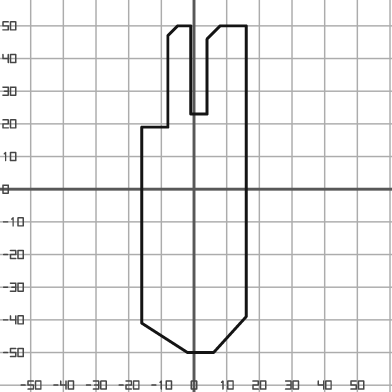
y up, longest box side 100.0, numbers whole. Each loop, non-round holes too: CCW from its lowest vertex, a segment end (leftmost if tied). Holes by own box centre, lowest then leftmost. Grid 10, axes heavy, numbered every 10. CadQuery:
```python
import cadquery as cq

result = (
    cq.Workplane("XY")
    .moveTo(-2.0, -50.0)
    .lineTo(6.0, -50.0)
    .lineTo(16.0, -39.0)
    .lineTo(16.0, 50.0)
    .lineTo(8.0, 50.0)
    .lineTo(4.0, 46.0)
    .lineTo(4.0, 23.0)
    .lineTo(-1.0, 23.0)
    .lineTo(-1.0, 50.0)
    .lineTo(-5.0, 50.0)
    .lineTo(-8.0, 47.0)
    .lineTo(-8.0, 19.0)
    .lineTo(-16.0, 19.0)
    .lineTo(-16.0, -41.0)
    .close()
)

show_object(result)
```